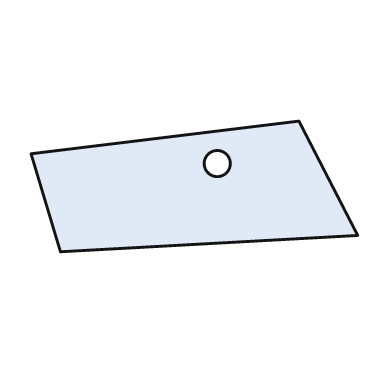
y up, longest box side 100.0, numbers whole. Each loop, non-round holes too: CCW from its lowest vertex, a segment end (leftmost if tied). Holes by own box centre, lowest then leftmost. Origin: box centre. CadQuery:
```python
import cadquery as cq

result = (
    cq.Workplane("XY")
    .moveTo(-41.0, -20.0)
    .lineTo(50.0, -15.0)
    .lineTo(32.0, 20.0)
    .lineTo(-50.0, 10.0)
    .close()
    .moveTo(7.0, 7.0)
    .circle(4.0)
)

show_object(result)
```